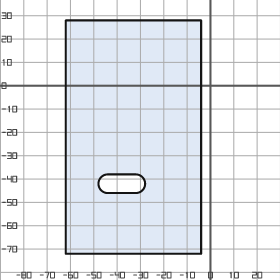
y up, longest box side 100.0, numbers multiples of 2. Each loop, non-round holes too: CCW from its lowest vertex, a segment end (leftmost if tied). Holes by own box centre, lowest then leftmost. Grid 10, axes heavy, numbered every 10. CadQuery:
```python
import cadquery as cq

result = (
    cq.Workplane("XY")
    .moveTo(-62.0, -72.0)
    .lineTo(-4.0, -72.0)
    .lineTo(-4.0, 28.0)
    .lineTo(-62.0, 28.0)
    .close()
    .moveTo(-44.0, -46.0)
    .lineTo(-32.0, -46.0)
    .threePointArc((-28.0, -42.0), (-32.0, -38.0))
    .lineTo(-44.0, -38.0)
    .threePointArc((-48.0, -42.0), (-44.0, -46.0))
    .close()
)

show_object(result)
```